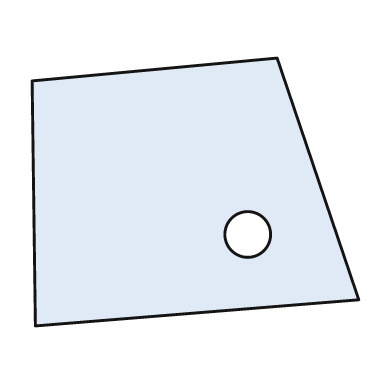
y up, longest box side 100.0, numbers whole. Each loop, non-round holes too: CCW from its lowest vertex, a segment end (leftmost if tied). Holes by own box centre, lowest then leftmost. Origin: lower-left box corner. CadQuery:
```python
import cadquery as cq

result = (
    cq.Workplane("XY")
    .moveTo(1.0, 0.0)
    .lineTo(100.0, 8.0)
    .lineTo(75.0, 82.0)
    .lineTo(0.0, 75.0)
    .close()
    .moveTo(66.0, 28.0)
    .circle(7.0)
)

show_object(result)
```